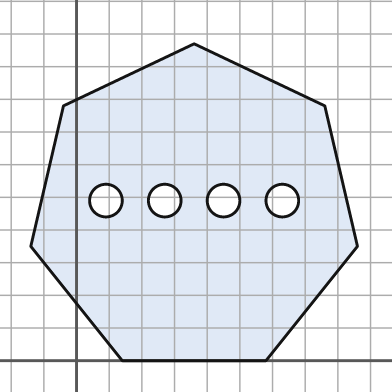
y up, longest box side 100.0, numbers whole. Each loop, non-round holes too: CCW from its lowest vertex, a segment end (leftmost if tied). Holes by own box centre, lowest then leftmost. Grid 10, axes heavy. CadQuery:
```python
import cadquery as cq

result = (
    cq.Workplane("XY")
    .moveTo(14.0, 0.0)
    .lineTo(58.0, 0.0)
    .lineTo(86.0, 35.0)
    .lineTo(76.0, 78.0)
    .lineTo(36.0, 97.0)
    .lineTo(-4.0, 78.0)
    .lineTo(-14.0, 35.0)
    .close()
    .moveTo(9.0, 49.0)
    .circle(5.0)
    .moveTo(27.0, 49.0)
    .circle(5.0)
    .moveTo(45.0, 49.0)
    .circle(5.0)
    .moveTo(63.0, 49.0)
    .circle(5.0)
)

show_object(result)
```